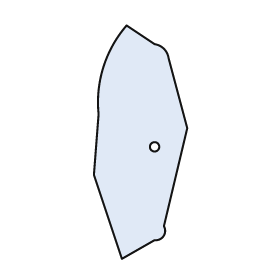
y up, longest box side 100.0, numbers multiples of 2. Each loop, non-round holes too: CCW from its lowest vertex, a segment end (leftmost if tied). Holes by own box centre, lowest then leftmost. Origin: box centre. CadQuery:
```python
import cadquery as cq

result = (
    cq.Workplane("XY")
    .moveTo(-8.0, -50.0)
    .lineTo(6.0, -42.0)
    .threePointArc((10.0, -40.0), (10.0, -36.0))
    .lineTo(20.0, 6.0)
    .lineTo(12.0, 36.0)
    .threePointArc((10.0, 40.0), (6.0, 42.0))
    .lineTo(-6.0, 50.0)
    .threePointArc((-16.0, 32.0), (-18.0, 12.0))
    .lineTo(-20.0, -14.0)
    .close()
    .moveTo(6.0, -2.0)
    .circle(2.0)
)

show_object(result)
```